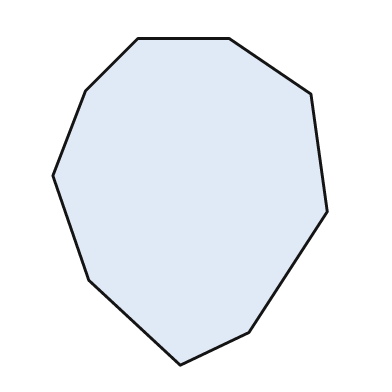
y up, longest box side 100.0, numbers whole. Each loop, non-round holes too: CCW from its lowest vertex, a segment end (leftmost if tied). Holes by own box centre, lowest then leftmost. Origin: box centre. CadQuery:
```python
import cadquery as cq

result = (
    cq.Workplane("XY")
    .moveTo(-3.0, -50.0)
    .lineTo(18.0, -40.0)
    .lineTo(42.0, -3.0)
    .lineTo(37.0, 33.0)
    .lineTo(12.0, 50.0)
    .lineTo(-16.0, 50.0)
    .lineTo(-32.0, 34.0)
    .lineTo(-42.0, 8.0)
    .lineTo(-31.0, -24.0)
    .close()
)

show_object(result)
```